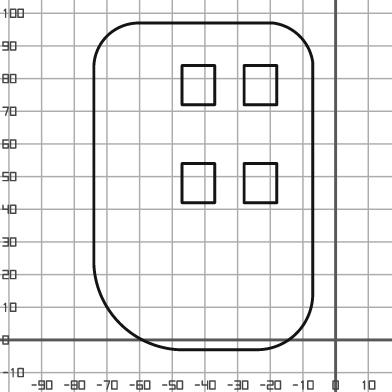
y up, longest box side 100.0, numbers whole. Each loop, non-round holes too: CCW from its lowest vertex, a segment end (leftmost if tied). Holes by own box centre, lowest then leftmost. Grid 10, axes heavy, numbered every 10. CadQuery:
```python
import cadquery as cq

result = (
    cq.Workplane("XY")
    .moveTo(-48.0, -3.0)
    .lineTo(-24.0, -3.0)
    .threePointArc((-12.0, 2.0), (-7.0, 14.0))
    .lineTo(-7.0, 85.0)
    .threePointArc((-11.0, 93.0), (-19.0, 97.0))
    .lineTo(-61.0, 97.0)
    .threePointArc((-70.0, 93.0), (-74.0, 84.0))
    .lineTo(-74.0, 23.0)
    .threePointArc((-66.0, 5.0), (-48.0, -3.0))
    .close()
    .moveTo(-47.0, 42.0)
    .lineTo(-37.0, 42.0)
    .lineTo(-37.0, 54.0)
    .lineTo(-47.0, 54.0)
    .close()
    .moveTo(-28.0, 42.0)
    .lineTo(-18.0, 42.0)
    .lineTo(-18.0, 54.0)
    .lineTo(-28.0, 54.0)
    .close()
    .moveTo(-47.0, 72.0)
    .lineTo(-37.0, 72.0)
    .lineTo(-37.0, 84.0)
    .lineTo(-47.0, 84.0)
    .close()
    .moveTo(-28.0, 72.0)
    .lineTo(-18.0, 72.0)
    .lineTo(-18.0, 84.0)
    .lineTo(-28.0, 84.0)
    .close()
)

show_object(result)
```